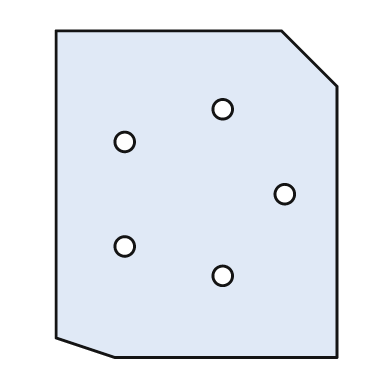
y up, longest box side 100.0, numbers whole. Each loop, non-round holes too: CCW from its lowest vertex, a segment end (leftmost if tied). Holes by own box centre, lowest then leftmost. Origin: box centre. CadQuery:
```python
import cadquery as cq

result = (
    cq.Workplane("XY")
    .moveTo(-25.0, -50.0)
    .lineTo(43.0, -50.0)
    .lineTo(43.0, 33.0)
    .lineTo(26.0, 50.0)
    .lineTo(-43.0, 50.0)
    .lineTo(-43.0, -44.0)
    .close()
    .moveTo(8.0, -25.0)
    .circle(3.0)
    .moveTo(-22.0, -16.0)
    .circle(3.0)
    .moveTo(27.0, 0.0)
    .circle(3.0)
    .moveTo(-22.0, 16.0)
    .circle(3.0)
    .moveTo(8.0, 26.0)
    .circle(3.0)
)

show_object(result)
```